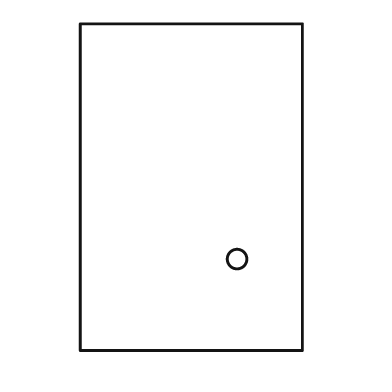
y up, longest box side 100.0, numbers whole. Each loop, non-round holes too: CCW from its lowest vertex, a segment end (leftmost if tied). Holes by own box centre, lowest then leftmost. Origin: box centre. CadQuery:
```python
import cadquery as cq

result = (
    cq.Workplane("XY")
    .moveTo(-34.0, -50.0)
    .lineTo(34.0, -50.0)
    .lineTo(34.0, 50.0)
    .lineTo(-34.0, 50.0)
    .close()
    .moveTo(14.0, -22.0)
    .circle(3.0)
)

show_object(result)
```